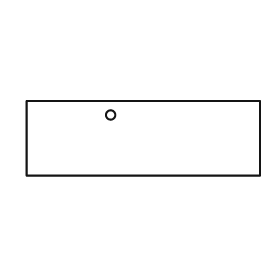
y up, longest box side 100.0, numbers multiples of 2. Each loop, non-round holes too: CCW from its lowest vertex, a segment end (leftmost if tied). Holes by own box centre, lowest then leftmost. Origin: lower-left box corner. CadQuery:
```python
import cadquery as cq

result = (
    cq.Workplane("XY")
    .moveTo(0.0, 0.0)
    .lineTo(100.0, 0.0)
    .lineTo(100.0, 32.0)
    .lineTo(0.0, 32.0)
    .close()
    .moveTo(36.0, 26.0)
    .circle(2.0)
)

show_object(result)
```